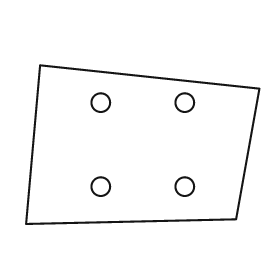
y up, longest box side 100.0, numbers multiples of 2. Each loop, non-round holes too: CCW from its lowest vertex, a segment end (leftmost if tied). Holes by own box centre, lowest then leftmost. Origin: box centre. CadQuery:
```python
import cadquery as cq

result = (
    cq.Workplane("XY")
    .moveTo(-50.0, -34.0)
    .lineTo(40.0, -32.0)
    .lineTo(50.0, 24.0)
    .lineTo(-44.0, 34.0)
    .close()
    .moveTo(-18.0, -18.0)
    .circle(4.0)
    .moveTo(18.0, -18.0)
    .circle(4.0)
    .moveTo(-18.0, 18.0)
    .circle(4.0)
    .moveTo(18.0, 18.0)
    .circle(4.0)
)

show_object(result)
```